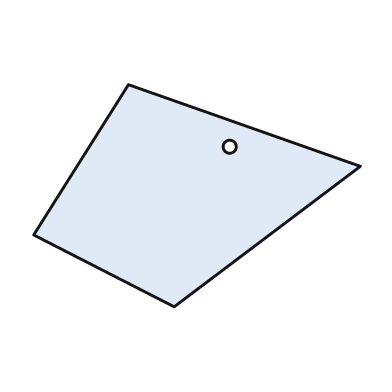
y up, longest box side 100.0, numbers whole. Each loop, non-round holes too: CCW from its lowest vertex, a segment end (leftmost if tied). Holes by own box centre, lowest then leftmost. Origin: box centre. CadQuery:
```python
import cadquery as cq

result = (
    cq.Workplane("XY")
    .moveTo(-7.0, -34.0)
    .lineTo(50.0, 9.0)
    .lineTo(-21.0, 34.0)
    .lineTo(-50.0, -12.0)
    .close()
    .moveTo(10.0, 15.0)
    .circle(2.0)
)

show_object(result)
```